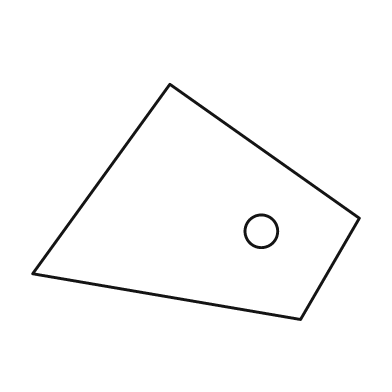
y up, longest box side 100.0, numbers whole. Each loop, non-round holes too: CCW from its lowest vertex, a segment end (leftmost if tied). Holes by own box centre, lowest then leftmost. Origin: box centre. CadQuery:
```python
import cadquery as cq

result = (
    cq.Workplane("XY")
    .moveTo(32.0, -36.0)
    .lineTo(50.0, -5.0)
    .lineTo(-8.0, 36.0)
    .lineTo(-50.0, -22.0)
    .close()
    .moveTo(20.0, -9.0)
    .circle(5.0)
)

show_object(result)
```